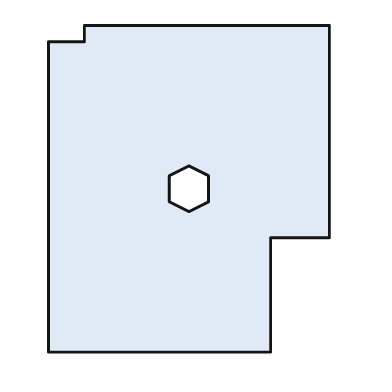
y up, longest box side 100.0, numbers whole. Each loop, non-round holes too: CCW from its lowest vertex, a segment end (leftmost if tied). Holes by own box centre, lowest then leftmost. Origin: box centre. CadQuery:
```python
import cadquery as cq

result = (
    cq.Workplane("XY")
    .moveTo(-43.0, -50.0)
    .lineTo(25.0, -50.0)
    .lineTo(25.0, -15.0)
    .lineTo(43.0, -15.0)
    .lineTo(43.0, 50.0)
    .lineTo(-32.0, 50.0)
    .lineTo(-32.0, 45.0)
    .lineTo(-43.0, 45.0)
    .close()
    .moveTo(0.0, -7.0)
    .lineTo(6.0, -4.0)
    .lineTo(6.0, 4.0)
    .lineTo(0.0, 7.0)
    .lineTo(-6.0, 4.0)
    .lineTo(-6.0, -4.0)
    .close()
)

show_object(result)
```